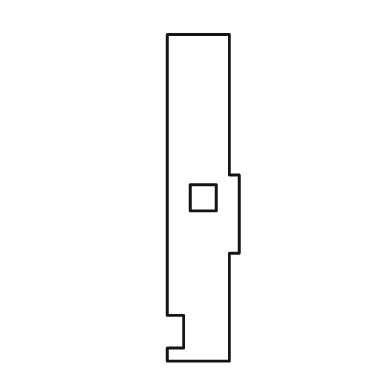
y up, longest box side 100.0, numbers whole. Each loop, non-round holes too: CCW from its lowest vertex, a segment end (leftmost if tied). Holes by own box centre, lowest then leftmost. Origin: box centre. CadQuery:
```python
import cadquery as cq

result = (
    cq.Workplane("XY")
    .moveTo(-11.0, -50.0)
    .lineTo(8.0, -50.0)
    .lineTo(8.0, -17.0)
    .lineTo(11.0, -17.0)
    .lineTo(11.0, 7.0)
    .lineTo(8.0, 7.0)
    .lineTo(8.0, 50.0)
    .lineTo(-11.0, 50.0)
    .lineTo(-11.0, -36.0)
    .lineTo(-6.0, -36.0)
    .lineTo(-6.0, -46.0)
    .lineTo(-11.0, -46.0)
    .close()
    .moveTo(-4.0, -4.0)
    .lineTo(4.0, -4.0)
    .lineTo(4.0, 4.0)
    .lineTo(-4.0, 4.0)
    .close()
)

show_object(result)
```